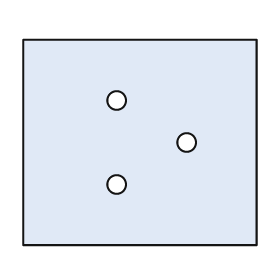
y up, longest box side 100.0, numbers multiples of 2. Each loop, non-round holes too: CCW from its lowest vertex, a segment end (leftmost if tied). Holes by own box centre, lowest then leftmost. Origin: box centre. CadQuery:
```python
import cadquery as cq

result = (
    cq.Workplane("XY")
    .moveTo(-50.0, -44.0)
    .lineTo(50.0, -44.0)
    .lineTo(50.0, 44.0)
    .lineTo(-50.0, 44.0)
    .close()
    .moveTo(-10.0, -18.0)
    .circle(4.0)
    .moveTo(20.0, 0.0)
    .circle(4.0)
    .moveTo(-10.0, 18.0)
    .circle(4.0)
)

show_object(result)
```